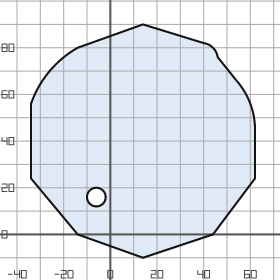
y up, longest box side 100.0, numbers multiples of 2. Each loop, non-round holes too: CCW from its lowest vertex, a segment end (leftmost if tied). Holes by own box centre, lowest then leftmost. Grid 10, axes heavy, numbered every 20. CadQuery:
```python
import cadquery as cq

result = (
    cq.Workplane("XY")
    .moveTo(14.0, -10.0)
    .lineTo(44.0, 0.0)
    .lineTo(62.0, 24.0)
    .lineTo(62.0, 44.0)
    .threePointArc((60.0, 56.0), (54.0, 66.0))
    .lineTo(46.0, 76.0)
    .threePointArc((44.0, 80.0), (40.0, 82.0))
    .lineTo(14.0, 90.0)
    .lineTo(-14.0, 80.0)
    .threePointArc((-26.0, 70.0), (-34.0, 56.0))
    .lineTo(-34.0, 24.0)
    .lineTo(-14.0, 0.0)
    .close()
    .moveTo(-6.0, 16.0)
    .circle(4.0)
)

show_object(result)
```